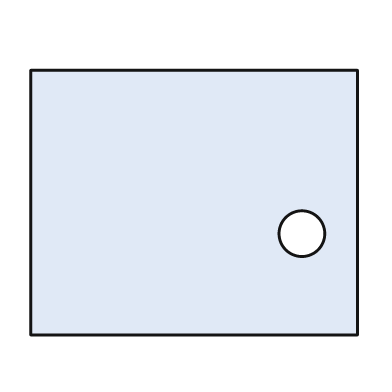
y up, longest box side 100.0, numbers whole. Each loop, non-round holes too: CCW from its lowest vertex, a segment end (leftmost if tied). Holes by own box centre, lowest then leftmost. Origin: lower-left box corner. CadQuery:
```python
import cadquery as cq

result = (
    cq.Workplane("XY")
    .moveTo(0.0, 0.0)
    .lineTo(100.0, 0.0)
    .lineTo(100.0, 81.0)
    .lineTo(0.0, 81.0)
    .close()
    .moveTo(83.0, 31.0)
    .circle(7.0)
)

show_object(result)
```